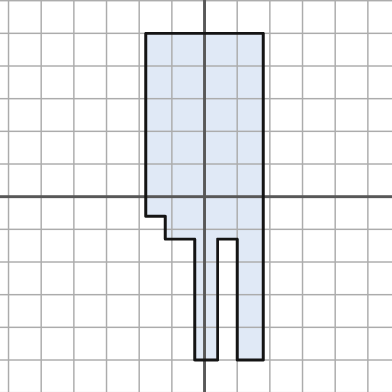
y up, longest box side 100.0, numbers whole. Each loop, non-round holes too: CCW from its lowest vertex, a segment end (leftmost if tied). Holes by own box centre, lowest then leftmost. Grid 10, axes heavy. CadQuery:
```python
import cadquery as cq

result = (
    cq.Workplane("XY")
    .moveTo(-3.0, -50.0)
    .lineTo(4.0, -50.0)
    .lineTo(4.0, -13.0)
    .lineTo(10.0, -13.0)
    .lineTo(10.0, -50.0)
    .lineTo(18.0, -50.0)
    .lineTo(18.0, 50.0)
    .lineTo(-18.0, 50.0)
    .lineTo(-18.0, -6.0)
    .lineTo(-12.0, -6.0)
    .lineTo(-12.0, -13.0)
    .lineTo(-3.0, -13.0)
    .close()
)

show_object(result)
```